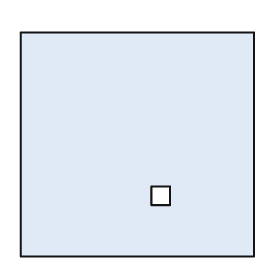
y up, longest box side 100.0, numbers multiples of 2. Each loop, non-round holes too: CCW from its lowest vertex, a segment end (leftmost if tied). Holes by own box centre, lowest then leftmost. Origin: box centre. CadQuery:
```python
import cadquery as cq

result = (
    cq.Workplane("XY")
    .moveTo(-50.0, -48.0)
    .lineTo(50.0, -48.0)
    .lineTo(50.0, 48.0)
    .lineTo(-50.0, 48.0)
    .close()
    .moveTo(6.0, -26.0)
    .lineTo(14.0, -26.0)
    .lineTo(14.0, -18.0)
    .lineTo(6.0, -18.0)
    .close()
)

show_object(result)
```